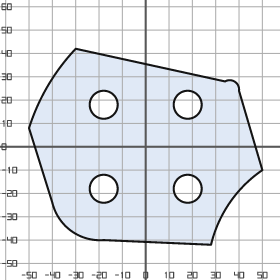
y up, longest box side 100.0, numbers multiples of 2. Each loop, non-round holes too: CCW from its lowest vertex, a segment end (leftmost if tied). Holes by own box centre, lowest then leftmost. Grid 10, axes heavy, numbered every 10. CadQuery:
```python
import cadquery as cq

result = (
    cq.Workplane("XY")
    .moveTo(28.0, -42.0)
    .threePointArc((36.0, -24.0), (50.0, -10.0))
    .lineTo(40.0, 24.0)
    .threePointArc((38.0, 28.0), (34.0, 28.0))
    .lineTo(-30.0, 42.0)
    .threePointArc((-42.0, 26.0), (-50.0, 8.0))
    .lineTo(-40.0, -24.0)
    .threePointArc((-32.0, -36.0), (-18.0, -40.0))
    .close()
    .moveTo(-18.0, -18.0)
    .circle(6.0)
    .moveTo(18.0, -18.0)
    .circle(6.0)
    .moveTo(-18.0, 18.0)
    .circle(6.0)
    .moveTo(18.0, 18.0)
    .circle(6.0)
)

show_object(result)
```